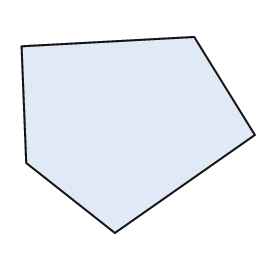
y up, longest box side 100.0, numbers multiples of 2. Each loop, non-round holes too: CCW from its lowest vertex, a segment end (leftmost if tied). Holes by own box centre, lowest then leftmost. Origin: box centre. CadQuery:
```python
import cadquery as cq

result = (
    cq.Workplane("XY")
    .moveTo(-10.0, -42.0)
    .lineTo(50.0, 0.0)
    .lineTo(24.0, 42.0)
    .lineTo(-50.0, 38.0)
    .lineTo(-48.0, -12.0)
    .close()
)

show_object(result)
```